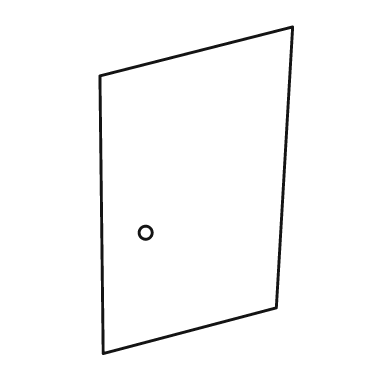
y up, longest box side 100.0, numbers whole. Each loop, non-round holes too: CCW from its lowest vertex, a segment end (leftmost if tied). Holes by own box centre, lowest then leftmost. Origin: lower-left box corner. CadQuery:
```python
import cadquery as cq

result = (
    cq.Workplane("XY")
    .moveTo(1.0, 0.0)
    .lineTo(54.0, 14.0)
    .lineTo(59.0, 100.0)
    .lineTo(0.0, 85.0)
    .close()
    .moveTo(14.0, 37.0)
    .circle(2.0)
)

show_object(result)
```